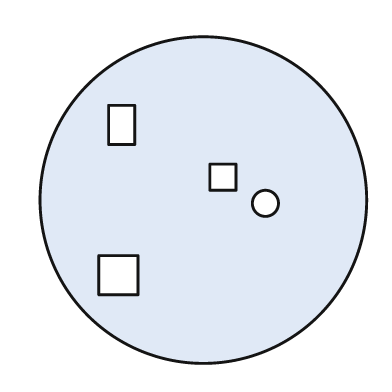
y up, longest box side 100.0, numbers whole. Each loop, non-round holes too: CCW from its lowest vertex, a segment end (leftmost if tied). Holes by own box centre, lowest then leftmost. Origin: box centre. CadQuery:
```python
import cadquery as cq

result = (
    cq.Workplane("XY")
    .moveTo(0.0, 0.0)
    .circle(50.0)
    .moveTo(-32.0, -29.0)
    .lineTo(-20.0, -29.0)
    .lineTo(-20.0, -17.0)
    .lineTo(-32.0, -17.0)
    .close()
    .moveTo(19.0, -1.0)
    .circle(4.0)
    .moveTo(2.0, 3.0)
    .lineTo(10.0, 3.0)
    .lineTo(10.0, 11.0)
    .lineTo(2.0, 11.0)
    .close()
    .moveTo(-29.0, 17.0)
    .lineTo(-21.0, 17.0)
    .lineTo(-21.0, 29.0)
    .lineTo(-29.0, 29.0)
    .close()
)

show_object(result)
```